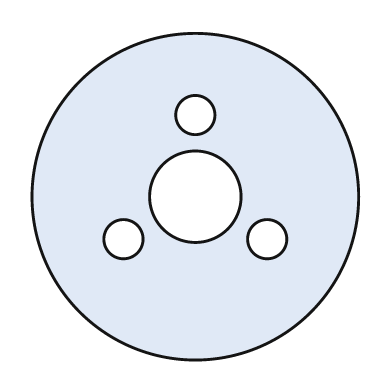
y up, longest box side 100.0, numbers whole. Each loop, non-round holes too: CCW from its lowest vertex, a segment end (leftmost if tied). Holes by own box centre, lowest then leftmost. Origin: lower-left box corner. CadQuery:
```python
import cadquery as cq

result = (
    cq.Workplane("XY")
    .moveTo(50.0, 50.0)
    .circle(50.0)
    .moveTo(28.0, 37.0)
    .circle(6.0)
    .moveTo(72.0, 37.0)
    .circle(6.0)
    .moveTo(50.0, 50.0)
    .circle(14.0)
    .moveTo(50.0, 75.0)
    .circle(6.0)
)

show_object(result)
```